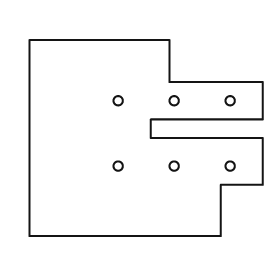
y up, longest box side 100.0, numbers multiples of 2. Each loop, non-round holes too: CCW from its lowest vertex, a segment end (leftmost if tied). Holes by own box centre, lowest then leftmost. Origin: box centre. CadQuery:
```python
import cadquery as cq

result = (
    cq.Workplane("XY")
    .moveTo(-50.0, -42.0)
    .lineTo(32.0, -42.0)
    .lineTo(32.0, -20.0)
    .lineTo(50.0, -20.0)
    .lineTo(50.0, 0.0)
    .lineTo(2.0, 0.0)
    .lineTo(2.0, 8.0)
    .lineTo(50.0, 8.0)
    .lineTo(50.0, 24.0)
    .lineTo(10.0, 24.0)
    .lineTo(10.0, 42.0)
    .lineTo(-50.0, 42.0)
    .close()
    .moveTo(-12.0, -12.0)
    .circle(2.0)
    .moveTo(12.0, -12.0)
    .circle(2.0)
    .moveTo(36.0, -12.0)
    .circle(2.0)
    .moveTo(-12.0, 16.0)
    .circle(2.0)
    .moveTo(12.0, 16.0)
    .circle(2.0)
    .moveTo(36.0, 16.0)
    .circle(2.0)
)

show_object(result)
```